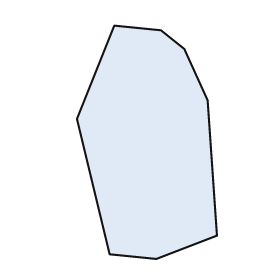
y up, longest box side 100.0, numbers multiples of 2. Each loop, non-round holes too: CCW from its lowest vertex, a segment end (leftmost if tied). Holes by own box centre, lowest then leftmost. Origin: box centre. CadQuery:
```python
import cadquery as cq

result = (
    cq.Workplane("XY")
    .moveTo(4.0, -50.0)
    .lineTo(30.0, -40.0)
    .lineTo(26.0, 18.0)
    .lineTo(16.0, 40.0)
    .lineTo(6.0, 48.0)
    .lineTo(-14.0, 50.0)
    .lineTo(-30.0, 10.0)
    .lineTo(-16.0, -48.0)
    .close()
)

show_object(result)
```